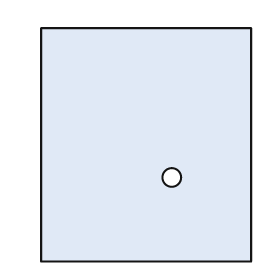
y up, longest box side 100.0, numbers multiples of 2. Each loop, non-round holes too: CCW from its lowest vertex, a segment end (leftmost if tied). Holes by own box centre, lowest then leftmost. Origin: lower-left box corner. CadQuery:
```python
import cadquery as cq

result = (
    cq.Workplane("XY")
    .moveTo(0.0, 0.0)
    .lineTo(90.0, 0.0)
    .lineTo(90.0, 100.0)
    .lineTo(0.0, 100.0)
    .close()
    .moveTo(56.0, 36.0)
    .circle(4.0)
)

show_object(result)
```